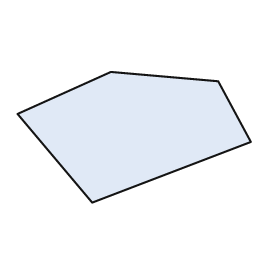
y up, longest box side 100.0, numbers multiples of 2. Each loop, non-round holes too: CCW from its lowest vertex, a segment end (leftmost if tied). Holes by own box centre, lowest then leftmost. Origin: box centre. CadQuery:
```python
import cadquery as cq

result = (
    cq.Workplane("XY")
    .moveTo(-18.0, -28.0)
    .lineTo(50.0, -2.0)
    .lineTo(36.0, 24.0)
    .lineTo(-10.0, 28.0)
    .lineTo(-50.0, 10.0)
    .close()
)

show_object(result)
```